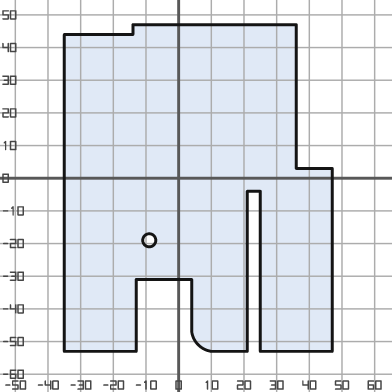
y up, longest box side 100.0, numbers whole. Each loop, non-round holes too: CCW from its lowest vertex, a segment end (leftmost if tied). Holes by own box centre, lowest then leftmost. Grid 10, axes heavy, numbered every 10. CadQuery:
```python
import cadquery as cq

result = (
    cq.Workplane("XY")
    .moveTo(-35.0, -53.0)
    .lineTo(-13.0, -53.0)
    .lineTo(-13.0, -31.0)
    .lineTo(4.0, -31.0)
    .lineTo(4.0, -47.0)
    .threePointArc((6.0, -51.0), (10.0, -53.0))
    .lineTo(21.0, -53.0)
    .lineTo(21.0, -4.0)
    .lineTo(25.0, -4.0)
    .lineTo(25.0, -53.0)
    .lineTo(47.0, -53.0)
    .lineTo(47.0, 3.0)
    .lineTo(36.0, 3.0)
    .lineTo(36.0, 47.0)
    .lineTo(-14.0, 47.0)
    .lineTo(-14.0, 44.0)
    .lineTo(-35.0, 44.0)
    .close()
    .moveTo(-9.0, -19.0)
    .circle(2.0)
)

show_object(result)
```